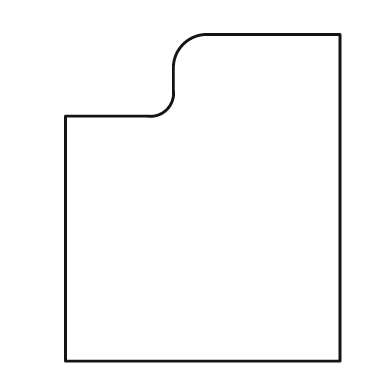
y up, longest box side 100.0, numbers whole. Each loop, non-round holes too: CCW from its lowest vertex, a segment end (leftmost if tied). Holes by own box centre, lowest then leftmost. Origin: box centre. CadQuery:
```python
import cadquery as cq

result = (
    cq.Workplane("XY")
    .moveTo(-42.0, -50.0)
    .lineTo(42.0, -50.0)
    .lineTo(42.0, 50.0)
    .lineTo(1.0, 50.0)
    .threePointArc((-6.0, 47.0), (-9.0, 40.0))
    .lineTo(-9.0, 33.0)
    .threePointArc((-11.0, 27.0), (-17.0, 25.0))
    .lineTo(-42.0, 25.0)
    .close()
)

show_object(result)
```